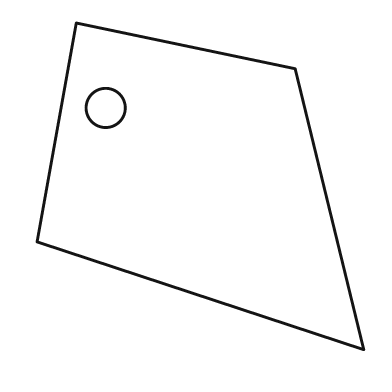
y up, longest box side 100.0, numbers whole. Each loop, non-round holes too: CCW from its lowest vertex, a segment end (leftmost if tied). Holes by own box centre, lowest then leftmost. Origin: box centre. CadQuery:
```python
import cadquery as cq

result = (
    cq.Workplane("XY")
    .moveTo(50.0, -50.0)
    .lineTo(29.0, 36.0)
    .lineTo(-38.0, 50.0)
    .lineTo(-50.0, -17.0)
    .close()
    .moveTo(-29.0, 24.0)
    .circle(6.0)
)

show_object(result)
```